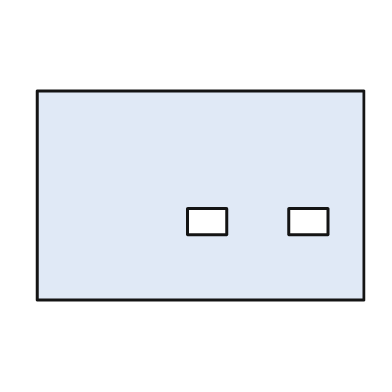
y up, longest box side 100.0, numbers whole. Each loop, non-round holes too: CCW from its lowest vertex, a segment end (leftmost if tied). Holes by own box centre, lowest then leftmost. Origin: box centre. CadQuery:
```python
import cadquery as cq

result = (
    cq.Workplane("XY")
    .moveTo(-50.0, -32.0)
    .lineTo(50.0, -32.0)
    .lineTo(50.0, 32.0)
    .lineTo(-50.0, 32.0)
    .close()
    .moveTo(-4.0, -12.0)
    .lineTo(8.0, -12.0)
    .lineTo(8.0, -4.0)
    .lineTo(-4.0, -4.0)
    .close()
    .moveTo(27.0, -12.0)
    .lineTo(39.0, -12.0)
    .lineTo(39.0, -4.0)
    .lineTo(27.0, -4.0)
    .close()
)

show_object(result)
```